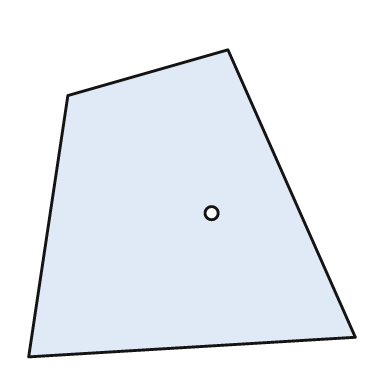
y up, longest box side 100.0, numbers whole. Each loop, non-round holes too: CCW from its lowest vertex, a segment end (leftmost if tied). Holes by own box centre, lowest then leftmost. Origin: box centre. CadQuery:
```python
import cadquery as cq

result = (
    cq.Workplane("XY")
    .moveTo(-50.0, -47.0)
    .lineTo(50.0, -41.0)
    .lineTo(11.0, 47.0)
    .lineTo(-38.0, 33.0)
    .close()
    .moveTo(6.0, -3.0)
    .circle(2.0)
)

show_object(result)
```